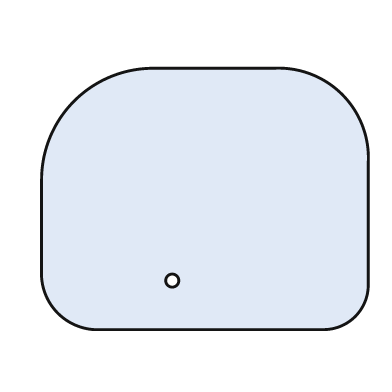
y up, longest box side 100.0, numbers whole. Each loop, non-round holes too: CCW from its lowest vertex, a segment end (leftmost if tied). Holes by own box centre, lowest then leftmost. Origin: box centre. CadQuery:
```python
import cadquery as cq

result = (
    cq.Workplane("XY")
    .moveTo(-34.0, -40.0)
    .lineTo(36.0, -40.0)
    .threePointArc((46.0, -36.0), (50.0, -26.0))
    .lineTo(50.0, 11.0)
    .threePointArc((42.0, 32.0), (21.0, 40.0))
    .lineTo(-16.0, 40.0)
    .threePointArc((-40.0, 30.0), (-50.0, 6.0))
    .lineTo(-50.0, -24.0)
    .threePointArc((-45.0, -35.0), (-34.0, -40.0))
    .close()
    .moveTo(-10.0, -25.0)
    .circle(2.0)
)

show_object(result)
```